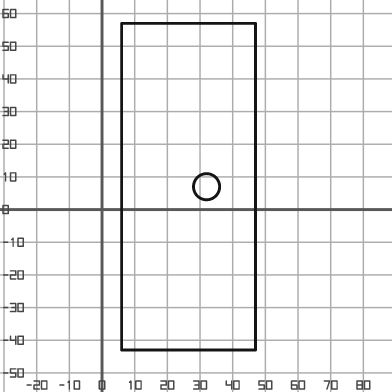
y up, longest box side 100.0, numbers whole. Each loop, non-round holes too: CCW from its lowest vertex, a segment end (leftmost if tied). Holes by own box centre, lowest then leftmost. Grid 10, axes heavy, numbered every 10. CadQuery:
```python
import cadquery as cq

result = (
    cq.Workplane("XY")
    .moveTo(6.0, -43.0)
    .lineTo(47.0, -43.0)
    .lineTo(47.0, 57.0)
    .lineTo(6.0, 57.0)
    .close()
    .moveTo(32.0, 7.0)
    .circle(4.0)
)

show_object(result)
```